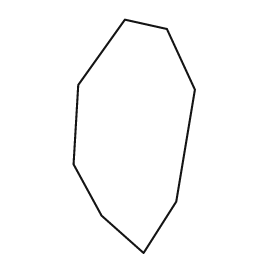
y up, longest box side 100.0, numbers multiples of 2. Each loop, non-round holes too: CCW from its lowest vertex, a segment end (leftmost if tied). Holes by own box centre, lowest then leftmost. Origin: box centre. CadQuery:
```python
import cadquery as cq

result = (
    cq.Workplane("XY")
    .moveTo(4.0, -50.0)
    .lineTo(18.0, -28.0)
    .lineTo(26.0, 20.0)
    .lineTo(14.0, 46.0)
    .lineTo(-4.0, 50.0)
    .lineTo(-24.0, 22.0)
    .lineTo(-26.0, -12.0)
    .lineTo(-14.0, -34.0)
    .close()
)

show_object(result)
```